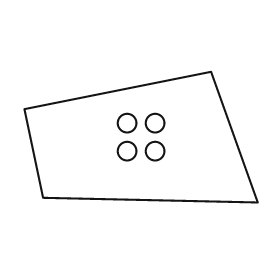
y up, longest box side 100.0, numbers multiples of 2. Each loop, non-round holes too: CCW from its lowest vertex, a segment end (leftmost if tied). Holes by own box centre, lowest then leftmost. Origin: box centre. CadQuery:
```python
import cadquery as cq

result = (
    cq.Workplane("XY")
    .moveTo(50.0, -28.0)
    .lineTo(30.0, 28.0)
    .lineTo(-50.0, 12.0)
    .lineTo(-42.0, -26.0)
    .close()
    .moveTo(-6.0, -6.0)
    .circle(4.0)
    .moveTo(6.0, -6.0)
    .circle(4.0)
    .moveTo(-6.0, 6.0)
    .circle(4.0)
    .moveTo(6.0, 6.0)
    .circle(4.0)
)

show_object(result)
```